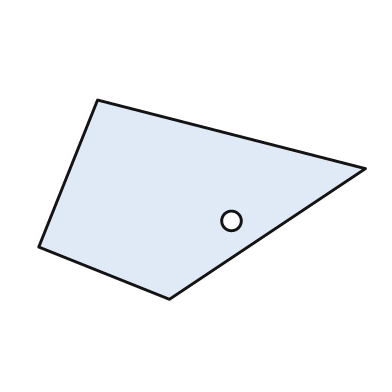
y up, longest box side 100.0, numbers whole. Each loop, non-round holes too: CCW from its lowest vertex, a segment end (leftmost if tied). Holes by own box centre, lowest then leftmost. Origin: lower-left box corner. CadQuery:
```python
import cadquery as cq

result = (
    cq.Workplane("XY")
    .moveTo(40.0, 0.0)
    .lineTo(100.0, 40.0)
    .lineTo(18.0, 61.0)
    .lineTo(0.0, 16.0)
    .close()
    .moveTo(59.0, 24.0)
    .circle(3.0)
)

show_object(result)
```